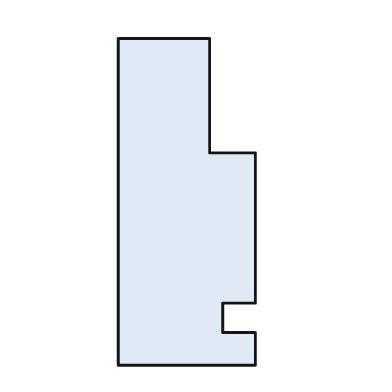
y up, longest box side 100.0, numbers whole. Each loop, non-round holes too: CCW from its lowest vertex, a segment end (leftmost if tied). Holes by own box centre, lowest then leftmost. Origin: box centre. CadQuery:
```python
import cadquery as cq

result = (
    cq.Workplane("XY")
    .moveTo(-21.0, -50.0)
    .lineTo(21.0, -50.0)
    .lineTo(21.0, -40.0)
    .lineTo(11.0, -40.0)
    .lineTo(11.0, -31.0)
    .lineTo(21.0, -31.0)
    .lineTo(21.0, 15.0)
    .lineTo(7.0, 15.0)
    .lineTo(7.0, 50.0)
    .lineTo(-21.0, 50.0)
    .close()
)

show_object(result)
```